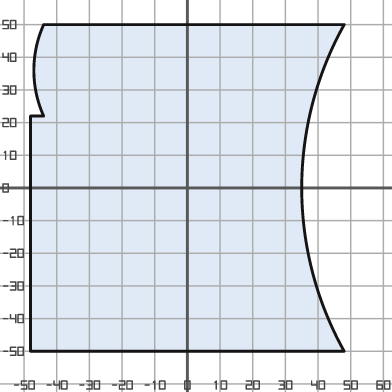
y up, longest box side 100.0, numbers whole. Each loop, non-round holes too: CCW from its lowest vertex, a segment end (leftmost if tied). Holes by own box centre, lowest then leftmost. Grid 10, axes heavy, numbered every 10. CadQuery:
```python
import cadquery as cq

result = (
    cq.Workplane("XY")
    .moveTo(-48.0, -50.0)
    .lineTo(48.0, -50.0)
    .threePointArc((35.0, 0.0), (48.0, 50.0))
    .lineTo(-44.0, 50.0)
    .threePointArc((-47.0, 36.0), (-44.0, 22.0))
    .lineTo(-48.0, 22.0)
    .close()
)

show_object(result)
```